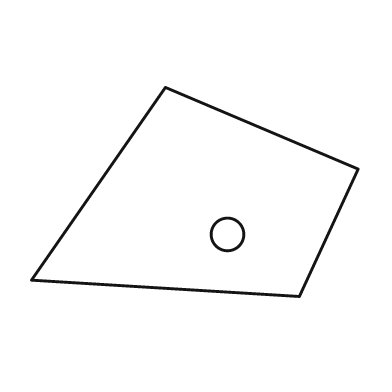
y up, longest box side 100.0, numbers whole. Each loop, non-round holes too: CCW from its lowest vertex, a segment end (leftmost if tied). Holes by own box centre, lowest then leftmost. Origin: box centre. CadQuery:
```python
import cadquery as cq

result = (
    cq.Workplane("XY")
    .moveTo(32.0, -32.0)
    .lineTo(50.0, 7.0)
    .lineTo(-9.0, 32.0)
    .lineTo(-50.0, -27.0)
    .close()
    .moveTo(10.0, -13.0)
    .circle(5.0)
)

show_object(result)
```